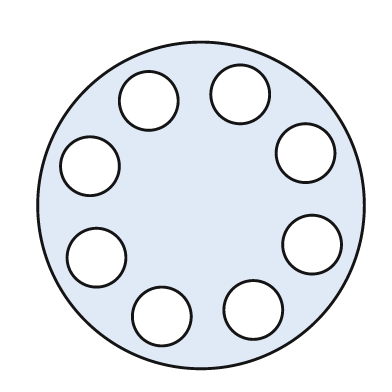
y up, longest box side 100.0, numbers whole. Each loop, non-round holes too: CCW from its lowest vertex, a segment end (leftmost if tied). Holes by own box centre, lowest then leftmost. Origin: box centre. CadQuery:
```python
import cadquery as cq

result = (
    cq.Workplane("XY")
    .moveTo(0.0, 0.0)
    .circle(50.0)
    .moveTo(-12.0, -34.0)
    .circle(9.0)
    .moveTo(16.0, -32.0)
    .circle(9.0)
    .moveTo(-32.0, -16.0)
    .circle(9.0)
    .moveTo(34.0, -12.0)
    .circle(9.0)
    .moveTo(-34.0, 12.0)
    .circle(9.0)
    .moveTo(32.0, 16.0)
    .circle(9.0)
    .moveTo(-16.0, 32.0)
    .circle(9.0)
    .moveTo(12.0, 34.0)
    .circle(9.0)
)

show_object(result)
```